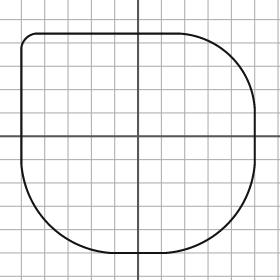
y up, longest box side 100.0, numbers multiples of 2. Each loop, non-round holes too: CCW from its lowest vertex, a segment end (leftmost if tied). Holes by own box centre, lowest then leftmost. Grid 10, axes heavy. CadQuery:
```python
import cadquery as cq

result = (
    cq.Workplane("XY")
    .moveTo(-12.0, -50.0)
    .lineTo(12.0, -50.0)
    .threePointArc((38.0, -38.0), (50.0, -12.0))
    .lineTo(50.0, 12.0)
    .threePointArc((40.0, 34.0), (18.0, 44.0))
    .lineTo(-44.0, 44.0)
    .threePointArc((-48.0, 42.0), (-50.0, 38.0))
    .lineTo(-50.0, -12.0)
    .threePointArc((-38.0, -38.0), (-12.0, -50.0))
    .close()
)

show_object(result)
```